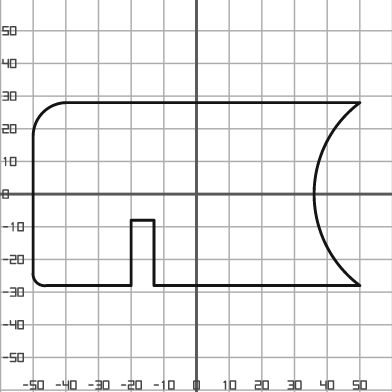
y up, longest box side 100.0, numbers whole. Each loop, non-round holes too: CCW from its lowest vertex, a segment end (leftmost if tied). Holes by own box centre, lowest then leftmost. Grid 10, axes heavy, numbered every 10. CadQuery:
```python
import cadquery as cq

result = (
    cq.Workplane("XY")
    .moveTo(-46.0, -28.0)
    .lineTo(-20.0, -28.0)
    .lineTo(-20.0, -8.0)
    .lineTo(-13.0, -8.0)
    .lineTo(-13.0, -28.0)
    .lineTo(50.0, -28.0)
    .threePointArc((36.0, 0.0), (50.0, 28.0))
    .lineTo(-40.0, 28.0)
    .threePointArc((-47.0, 25.0), (-50.0, 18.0))
    .lineTo(-50.0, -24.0)
    .threePointArc((-49.0, -27.0), (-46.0, -28.0))
    .close()
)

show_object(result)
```